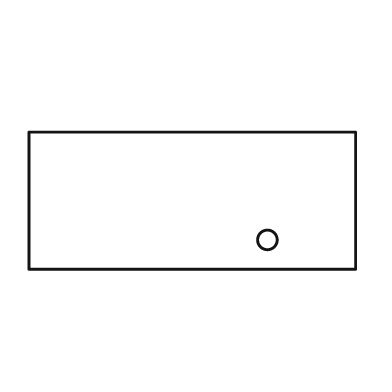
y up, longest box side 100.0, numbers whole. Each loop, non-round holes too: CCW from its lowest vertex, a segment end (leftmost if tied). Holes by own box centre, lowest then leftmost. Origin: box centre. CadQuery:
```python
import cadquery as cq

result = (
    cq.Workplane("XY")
    .moveTo(-50.0, -21.0)
    .lineTo(50.0, -21.0)
    .lineTo(50.0, 21.0)
    .lineTo(-50.0, 21.0)
    .close()
    .moveTo(23.0, -12.0)
    .circle(3.0)
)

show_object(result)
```